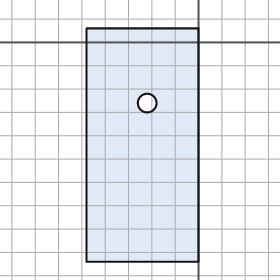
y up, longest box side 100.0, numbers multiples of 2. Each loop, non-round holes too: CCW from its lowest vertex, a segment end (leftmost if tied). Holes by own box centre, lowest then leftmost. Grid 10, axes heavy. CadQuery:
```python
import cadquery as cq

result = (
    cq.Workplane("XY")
    .moveTo(-48.0, -94.0)
    .lineTo(0.0, -94.0)
    .lineTo(0.0, 6.0)
    .lineTo(-48.0, 6.0)
    .close()
    .moveTo(-22.0, -26.0)
    .circle(4.0)
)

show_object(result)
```